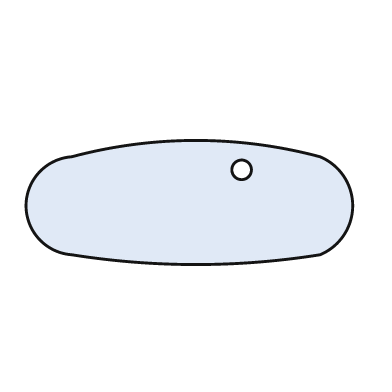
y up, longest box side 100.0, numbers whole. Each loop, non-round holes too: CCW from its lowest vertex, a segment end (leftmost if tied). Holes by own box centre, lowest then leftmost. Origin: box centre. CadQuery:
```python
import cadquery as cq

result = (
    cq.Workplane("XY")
    .moveTo(-36.0, -16.0)
    .threePointArc((2.0, -19.0), (40.0, -16.0))
    .threePointArc((50.0, -1.0), (40.0, 14.0))
    .threePointArc((2.0, 19.0), (-36.0, 14.0))
    .threePointArc((-50.0, -1.0), (-36.0, -16.0))
    .close()
    .moveTo(16.0, 10.0)
    .circle(3.0)
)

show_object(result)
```